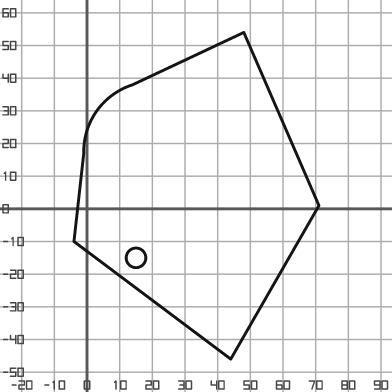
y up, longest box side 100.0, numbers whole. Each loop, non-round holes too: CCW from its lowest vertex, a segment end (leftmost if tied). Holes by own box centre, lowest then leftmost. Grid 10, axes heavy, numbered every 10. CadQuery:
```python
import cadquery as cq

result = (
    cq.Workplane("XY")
    .moveTo(44.0, -46.0)
    .lineTo(71.0, 1.0)
    .lineTo(48.0, 54.0)
    .lineTo(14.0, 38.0)
    .threePointArc((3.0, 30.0), (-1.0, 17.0))
    .lineTo(-4.0, -10.0)
    .close()
    .moveTo(15.0, -15.0)
    .circle(3.0)
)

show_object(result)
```